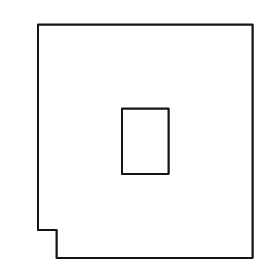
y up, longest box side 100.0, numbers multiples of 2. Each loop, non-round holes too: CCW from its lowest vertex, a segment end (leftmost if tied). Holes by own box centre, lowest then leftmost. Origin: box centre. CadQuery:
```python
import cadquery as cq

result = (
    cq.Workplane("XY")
    .moveTo(-38.0, -50.0)
    .lineTo(46.0, -50.0)
    .lineTo(46.0, 50.0)
    .lineTo(-46.0, 50.0)
    .lineTo(-46.0, -38.0)
    .lineTo(-38.0, -38.0)
    .close()
    .moveTo(-10.0, -14.0)
    .lineTo(10.0, -14.0)
    .lineTo(10.0, 14.0)
    .lineTo(-10.0, 14.0)
    .close()
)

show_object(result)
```